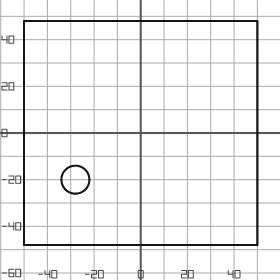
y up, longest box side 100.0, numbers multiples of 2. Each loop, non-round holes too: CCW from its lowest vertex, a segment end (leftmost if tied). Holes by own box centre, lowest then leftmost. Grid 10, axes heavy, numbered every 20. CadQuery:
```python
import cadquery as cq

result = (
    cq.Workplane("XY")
    .moveTo(-50.0, -48.0)
    .lineTo(50.0, -48.0)
    .lineTo(50.0, 48.0)
    .lineTo(-50.0, 48.0)
    .close()
    .moveTo(-28.0, -20.0)
    .circle(6.0)
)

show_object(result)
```